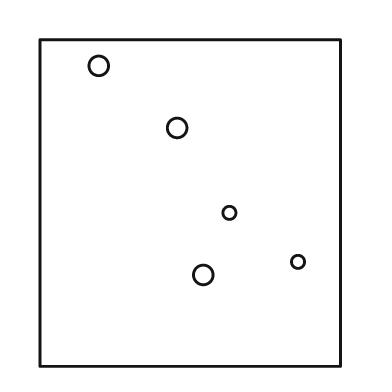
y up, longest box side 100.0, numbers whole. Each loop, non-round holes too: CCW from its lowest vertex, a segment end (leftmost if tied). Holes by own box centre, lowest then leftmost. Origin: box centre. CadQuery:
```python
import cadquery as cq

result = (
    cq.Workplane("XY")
    .moveTo(-46.0, -50.0)
    .lineTo(46.0, -50.0)
    .lineTo(46.0, 50.0)
    .lineTo(-46.0, 50.0)
    .close()
    .moveTo(4.0, -22.0)
    .circle(3.0)
    .moveTo(33.0, -18.0)
    .circle(2.0)
    .moveTo(12.0, -3.0)
    .circle(2.0)
    .moveTo(-4.0, 23.0)
    .circle(3.0)
    .moveTo(-28.0, 42.0)
    .circle(3.0)
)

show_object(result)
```